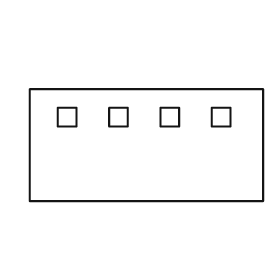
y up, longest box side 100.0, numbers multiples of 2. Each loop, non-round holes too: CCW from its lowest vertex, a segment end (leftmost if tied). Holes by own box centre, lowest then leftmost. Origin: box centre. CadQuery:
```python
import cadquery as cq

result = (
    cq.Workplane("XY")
    .moveTo(-50.0, -24.0)
    .lineTo(50.0, -24.0)
    .lineTo(50.0, 24.0)
    .lineTo(-50.0, 24.0)
    .close()
    .moveTo(-38.0, 8.0)
    .lineTo(-30.0, 8.0)
    .lineTo(-30.0, 16.0)
    .lineTo(-38.0, 16.0)
    .close()
    .moveTo(-16.0, 8.0)
    .lineTo(-8.0, 8.0)
    .lineTo(-8.0, 16.0)
    .lineTo(-16.0, 16.0)
    .close()
    .moveTo(6.0, 8.0)
    .lineTo(14.0, 8.0)
    .lineTo(14.0, 16.0)
    .lineTo(6.0, 16.0)
    .close()
    .moveTo(28.0, 8.0)
    .lineTo(36.0, 8.0)
    .lineTo(36.0, 16.0)
    .lineTo(28.0, 16.0)
    .close()
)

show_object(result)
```